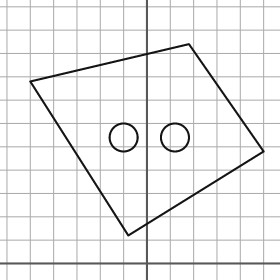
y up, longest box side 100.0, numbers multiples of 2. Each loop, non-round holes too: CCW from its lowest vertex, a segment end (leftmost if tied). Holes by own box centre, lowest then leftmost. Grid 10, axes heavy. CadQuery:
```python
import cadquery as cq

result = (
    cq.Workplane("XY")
    .moveTo(-8.0, 12.0)
    .lineTo(50.0, 48.0)
    .lineTo(18.0, 94.0)
    .lineTo(-50.0, 78.0)
    .close()
    .moveTo(-10.0, 54.0)
    .circle(6.0)
    .moveTo(12.0, 54.0)
    .circle(6.0)
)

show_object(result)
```